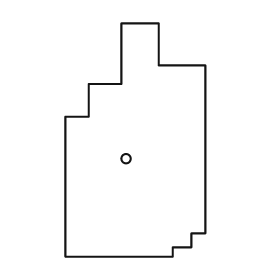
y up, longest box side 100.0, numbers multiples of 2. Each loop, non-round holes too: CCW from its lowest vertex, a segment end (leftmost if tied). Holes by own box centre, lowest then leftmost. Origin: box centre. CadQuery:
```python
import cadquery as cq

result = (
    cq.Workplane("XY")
    .moveTo(-30.0, -50.0)
    .lineTo(16.0, -50.0)
    .lineTo(16.0, -46.0)
    .lineTo(24.0, -46.0)
    .lineTo(24.0, -40.0)
    .lineTo(30.0, -40.0)
    .lineTo(30.0, 32.0)
    .lineTo(10.0, 32.0)
    .lineTo(10.0, 50.0)
    .lineTo(-6.0, 50.0)
    .lineTo(-6.0, 24.0)
    .lineTo(-20.0, 24.0)
    .lineTo(-20.0, 10.0)
    .lineTo(-30.0, 10.0)
    .close()
    .moveTo(-4.0, -8.0)
    .circle(2.0)
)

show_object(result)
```